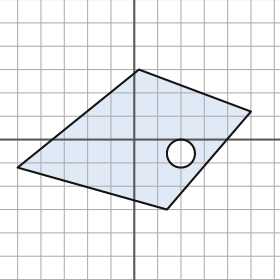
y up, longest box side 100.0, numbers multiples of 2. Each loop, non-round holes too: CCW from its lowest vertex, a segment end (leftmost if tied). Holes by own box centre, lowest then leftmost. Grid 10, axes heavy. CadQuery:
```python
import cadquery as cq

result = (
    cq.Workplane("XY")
    .moveTo(14.0, -30.0)
    .lineTo(50.0, 12.0)
    .lineTo(2.0, 30.0)
    .lineTo(-50.0, -12.0)
    .close()
    .moveTo(20.0, -6.0)
    .circle(6.0)
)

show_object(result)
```